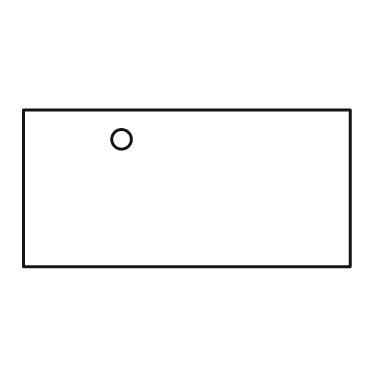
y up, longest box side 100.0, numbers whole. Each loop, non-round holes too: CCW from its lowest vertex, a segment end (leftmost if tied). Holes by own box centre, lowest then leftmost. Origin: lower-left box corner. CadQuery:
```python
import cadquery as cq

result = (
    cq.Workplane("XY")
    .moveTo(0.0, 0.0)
    .lineTo(100.0, 0.0)
    .lineTo(100.0, 48.0)
    .lineTo(0.0, 48.0)
    .close()
    .moveTo(30.0, 39.0)
    .circle(3.0)
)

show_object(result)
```